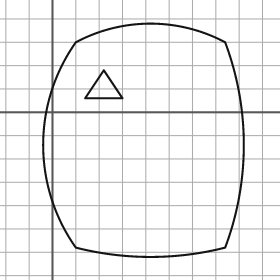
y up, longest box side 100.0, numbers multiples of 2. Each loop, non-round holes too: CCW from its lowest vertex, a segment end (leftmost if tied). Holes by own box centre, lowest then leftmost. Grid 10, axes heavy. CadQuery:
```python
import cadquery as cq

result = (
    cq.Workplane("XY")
    .moveTo(10.0, -58.0)
    .threePointArc((42.0, -62.0), (74.0, -58.0))
    .threePointArc((82.0, -14.0), (74.0, 30.0))
    .threePointArc((42.0, 38.0), (10.0, 30.0))
    .threePointArc((-4.0, -14.0), (10.0, -58.0))
    .close()
    .moveTo(14.0, 6.0)
    .lineTo(30.0, 6.0)
    .lineTo(22.0, 18.0)
    .close()
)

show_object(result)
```